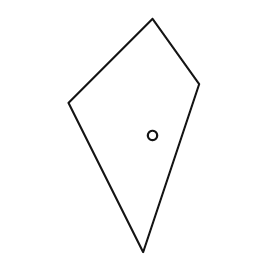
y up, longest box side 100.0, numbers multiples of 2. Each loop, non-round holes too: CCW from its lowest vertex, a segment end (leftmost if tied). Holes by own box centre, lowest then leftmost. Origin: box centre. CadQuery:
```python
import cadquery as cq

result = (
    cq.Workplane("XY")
    .moveTo(4.0, -50.0)
    .lineTo(28.0, 22.0)
    .lineTo(8.0, 50.0)
    .lineTo(-28.0, 14.0)
    .close()
    .moveTo(8.0, 0.0)
    .circle(2.0)
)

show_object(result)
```